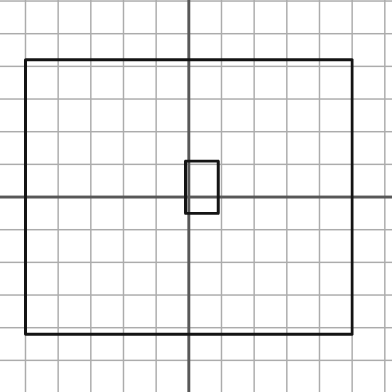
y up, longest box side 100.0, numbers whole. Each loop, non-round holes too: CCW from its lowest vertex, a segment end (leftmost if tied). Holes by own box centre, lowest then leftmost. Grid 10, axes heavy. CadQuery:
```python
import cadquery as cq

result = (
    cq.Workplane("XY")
    .moveTo(-50.0, -42.0)
    .lineTo(50.0, -42.0)
    .lineTo(50.0, 42.0)
    .lineTo(-50.0, 42.0)
    .close()
    .moveTo(-1.0, -5.0)
    .lineTo(9.0, -5.0)
    .lineTo(9.0, 11.0)
    .lineTo(-1.0, 11.0)
    .close()
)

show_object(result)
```